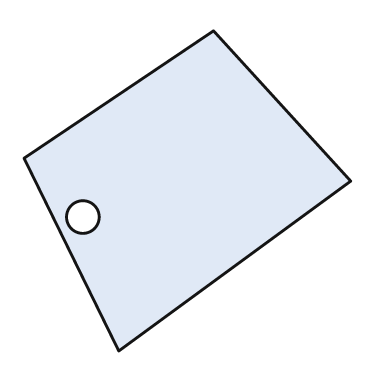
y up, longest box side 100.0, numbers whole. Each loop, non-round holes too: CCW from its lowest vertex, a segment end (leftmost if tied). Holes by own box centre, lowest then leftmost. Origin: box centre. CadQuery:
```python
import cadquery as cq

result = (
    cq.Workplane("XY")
    .moveTo(-21.0, -49.0)
    .lineTo(50.0, 3.0)
    .lineTo(8.0, 49.0)
    .lineTo(-50.0, 10.0)
    .close()
    .moveTo(-32.0, -8.0)
    .circle(5.0)
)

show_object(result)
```